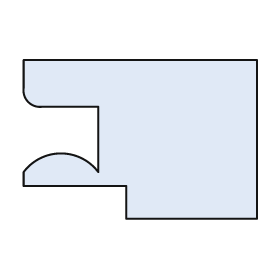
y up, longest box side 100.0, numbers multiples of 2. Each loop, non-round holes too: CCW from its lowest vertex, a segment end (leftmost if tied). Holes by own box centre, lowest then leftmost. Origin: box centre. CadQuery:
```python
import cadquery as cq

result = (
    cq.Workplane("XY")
    .moveTo(-6.0, -34.0)
    .lineTo(50.0, -34.0)
    .lineTo(50.0, 34.0)
    .lineTo(-50.0, 34.0)
    .lineTo(-50.0, 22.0)
    .threePointArc((-48.0, 16.0), (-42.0, 14.0))
    .lineTo(-18.0, 14.0)
    .lineTo(-18.0, -14.0)
    .threePointArc((-34.0, -6.0), (-50.0, -14.0))
    .lineTo(-50.0, -20.0)
    .lineTo(-6.0, -20.0)
    .close()
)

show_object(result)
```